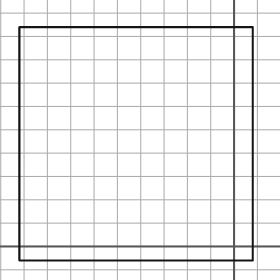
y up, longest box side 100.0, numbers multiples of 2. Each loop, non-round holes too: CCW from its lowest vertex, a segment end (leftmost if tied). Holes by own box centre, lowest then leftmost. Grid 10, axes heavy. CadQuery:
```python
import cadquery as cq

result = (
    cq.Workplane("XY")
    .moveTo(-92.0, -6.0)
    .lineTo(8.0, -6.0)
    .lineTo(8.0, 94.0)
    .lineTo(-92.0, 94.0)
    .close()
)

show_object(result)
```